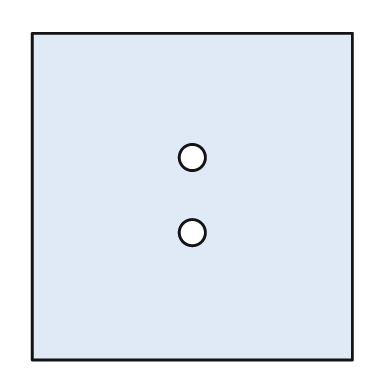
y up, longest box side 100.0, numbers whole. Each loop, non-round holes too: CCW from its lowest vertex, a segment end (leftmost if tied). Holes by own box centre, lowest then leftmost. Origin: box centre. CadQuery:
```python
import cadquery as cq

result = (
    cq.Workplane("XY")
    .moveTo(-49.0, -50.0)
    .lineTo(49.0, -50.0)
    .lineTo(49.0, 50.0)
    .lineTo(-49.0, 50.0)
    .close()
    .moveTo(0.0, -11.0)
    .circle(4.0)
    .moveTo(0.0, 12.0)
    .circle(4.0)
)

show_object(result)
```